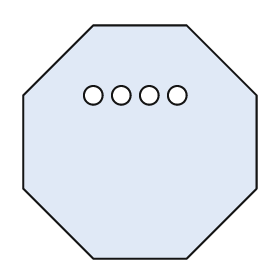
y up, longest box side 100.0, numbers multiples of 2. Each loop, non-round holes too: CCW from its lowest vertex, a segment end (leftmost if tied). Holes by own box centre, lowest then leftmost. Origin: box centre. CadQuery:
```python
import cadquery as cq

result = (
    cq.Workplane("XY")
    .moveTo(-20.0, -50.0)
    .lineTo(20.0, -50.0)
    .lineTo(50.0, -20.0)
    .lineTo(50.0, 20.0)
    .lineTo(20.0, 50.0)
    .lineTo(-20.0, 50.0)
    .lineTo(-50.0, 20.0)
    .lineTo(-50.0, -20.0)
    .close()
    .moveTo(-20.0, 20.0)
    .circle(4.0)
    .moveTo(-8.0, 20.0)
    .circle(4.0)
    .moveTo(4.0, 20.0)
    .circle(4.0)
    .moveTo(16.0, 20.0)
    .circle(4.0)
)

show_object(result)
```